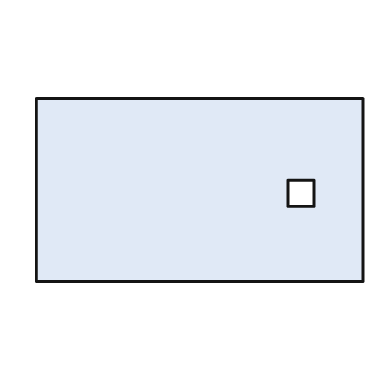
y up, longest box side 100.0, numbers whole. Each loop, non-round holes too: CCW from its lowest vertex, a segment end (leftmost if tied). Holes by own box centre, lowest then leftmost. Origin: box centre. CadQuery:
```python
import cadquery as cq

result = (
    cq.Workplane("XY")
    .moveTo(-50.0, -28.0)
    .lineTo(50.0, -28.0)
    .lineTo(50.0, 28.0)
    .lineTo(-50.0, 28.0)
    .close()
    .moveTo(27.0, -5.0)
    .lineTo(35.0, -5.0)
    .lineTo(35.0, 3.0)
    .lineTo(27.0, 3.0)
    .close()
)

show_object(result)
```